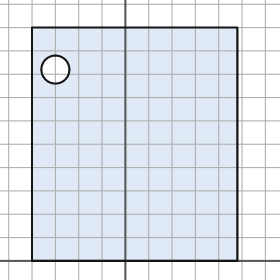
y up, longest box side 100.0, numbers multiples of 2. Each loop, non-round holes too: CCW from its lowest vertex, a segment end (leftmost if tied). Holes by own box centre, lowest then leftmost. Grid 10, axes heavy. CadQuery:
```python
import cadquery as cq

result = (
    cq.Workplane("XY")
    .moveTo(-40.0, 0.0)
    .lineTo(48.0, 0.0)
    .lineTo(48.0, 100.0)
    .lineTo(-40.0, 100.0)
    .close()
    .moveTo(-30.0, 82.0)
    .circle(6.0)
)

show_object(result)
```